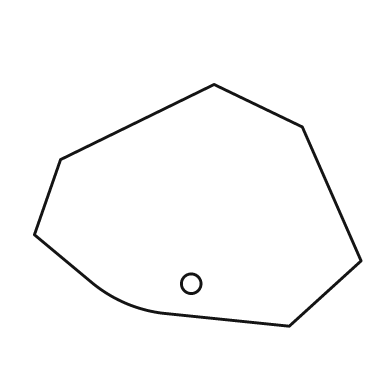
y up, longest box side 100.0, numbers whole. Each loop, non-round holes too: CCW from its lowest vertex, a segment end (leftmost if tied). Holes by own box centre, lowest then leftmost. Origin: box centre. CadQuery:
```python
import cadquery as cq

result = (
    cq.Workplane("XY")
    .moveTo(28.0, -37.0)
    .lineTo(50.0, -17.0)
    .lineTo(32.0, 24.0)
    .lineTo(5.0, 37.0)
    .lineTo(-42.0, 14.0)
    .lineTo(-50.0, -9.0)
    .lineTo(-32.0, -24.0)
    .threePointArc((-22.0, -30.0), (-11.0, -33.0))
    .close()
    .moveTo(-2.0, -24.0)
    .circle(3.0)
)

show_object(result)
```